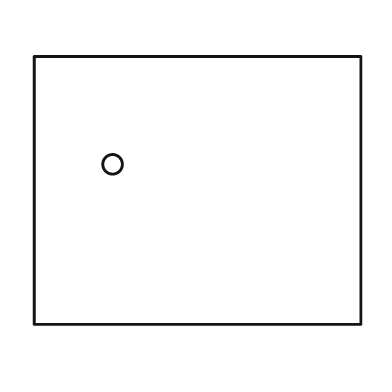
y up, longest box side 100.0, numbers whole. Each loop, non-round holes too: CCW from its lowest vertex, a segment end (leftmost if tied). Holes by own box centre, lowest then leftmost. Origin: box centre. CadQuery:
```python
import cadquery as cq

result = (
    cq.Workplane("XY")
    .moveTo(-50.0, -41.0)
    .lineTo(50.0, -41.0)
    .lineTo(50.0, 41.0)
    .lineTo(-50.0, 41.0)
    .close()
    .moveTo(-26.0, 8.0)
    .circle(3.0)
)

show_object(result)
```